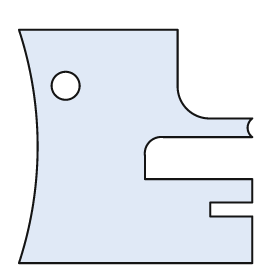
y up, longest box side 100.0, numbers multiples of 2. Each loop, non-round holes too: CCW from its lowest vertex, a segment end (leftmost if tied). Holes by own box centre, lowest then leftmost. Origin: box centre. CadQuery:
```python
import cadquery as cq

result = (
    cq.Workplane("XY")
    .moveTo(-50.0, -50.0)
    .lineTo(50.0, -50.0)
    .lineTo(50.0, -30.0)
    .lineTo(32.0, -30.0)
    .lineTo(32.0, -24.0)
    .lineTo(50.0, -24.0)
    .lineTo(50.0, -14.0)
    .lineTo(4.0, -14.0)
    .lineTo(4.0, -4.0)
    .threePointArc((6.0, 2.0), (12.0, 4.0))
    .lineTo(50.0, 4.0)
    .threePointArc((48.0, 8.0), (50.0, 12.0))
    .lineTo(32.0, 12.0)
    .threePointArc((22.0, 16.0), (18.0, 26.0))
    .lineTo(18.0, 50.0)
    .lineTo(-50.0, 50.0)
    .threePointArc((-42.0, 0.0), (-50.0, -50.0))
    .close()
    .moveTo(-30.0, 26.0)
    .circle(6.0)
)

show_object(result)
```